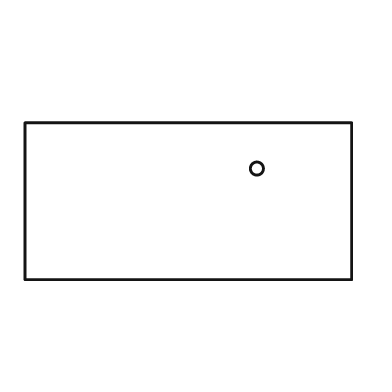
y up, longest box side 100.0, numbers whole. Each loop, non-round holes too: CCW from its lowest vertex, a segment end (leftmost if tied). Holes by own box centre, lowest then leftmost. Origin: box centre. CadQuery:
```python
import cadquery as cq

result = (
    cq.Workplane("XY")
    .moveTo(-50.0, -24.0)
    .lineTo(50.0, -24.0)
    .lineTo(50.0, 24.0)
    .lineTo(-50.0, 24.0)
    .close()
    .moveTo(21.0, 10.0)
    .circle(2.0)
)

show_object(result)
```